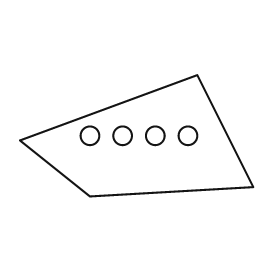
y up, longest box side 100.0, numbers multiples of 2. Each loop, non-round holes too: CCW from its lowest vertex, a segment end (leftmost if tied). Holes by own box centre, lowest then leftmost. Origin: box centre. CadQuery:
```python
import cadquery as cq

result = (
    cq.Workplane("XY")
    .moveTo(-20.0, -26.0)
    .lineTo(50.0, -22.0)
    .lineTo(26.0, 26.0)
    .lineTo(-50.0, -2.0)
    .close()
    .moveTo(-20.0, 0.0)
    .circle(4.0)
    .moveTo(-6.0, 0.0)
    .circle(4.0)
    .moveTo(8.0, 0.0)
    .circle(4.0)
    .moveTo(22.0, 0.0)
    .circle(4.0)
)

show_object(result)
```